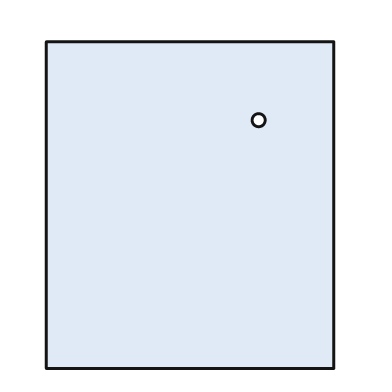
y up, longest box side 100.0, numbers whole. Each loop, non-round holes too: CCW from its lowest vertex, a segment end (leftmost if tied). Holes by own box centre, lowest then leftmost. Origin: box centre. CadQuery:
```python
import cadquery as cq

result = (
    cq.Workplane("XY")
    .moveTo(-44.0, -50.0)
    .lineTo(44.0, -50.0)
    .lineTo(44.0, 50.0)
    .lineTo(-44.0, 50.0)
    .close()
    .moveTo(21.0, 26.0)
    .circle(2.0)
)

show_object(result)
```